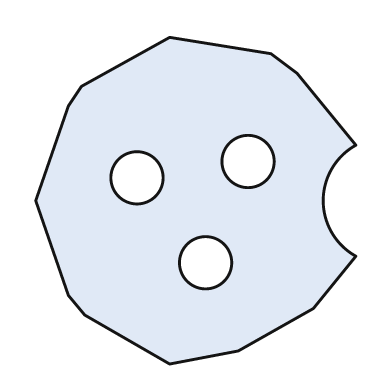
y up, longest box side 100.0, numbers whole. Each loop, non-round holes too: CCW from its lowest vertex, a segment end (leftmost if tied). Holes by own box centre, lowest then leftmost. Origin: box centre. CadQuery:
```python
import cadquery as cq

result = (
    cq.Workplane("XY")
    .moveTo(-8.0, -50.0)
    .lineTo(13.0, -46.0)
    .lineTo(36.0, -33.0)
    .lineTo(49.0, -17.0)
    .threePointArc((39.0, 0.0), (49.0, 17.0))
    .lineTo(31.0, 39.0)
    .lineTo(23.0, 45.0)
    .lineTo(-8.0, 50.0)
    .lineTo(-35.0, 35.0)
    .lineTo(-39.0, 29.0)
    .lineTo(-49.0, 0.0)
    .lineTo(-39.0, -29.0)
    .lineTo(-34.0, -35.0)
    .close()
    .moveTo(3.0, -19.0)
    .circle(8.0)
    .moveTo(-18.0, 7.0)
    .circle(8.0)
    .moveTo(16.0, 12.0)
    .circle(8.0)
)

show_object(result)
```